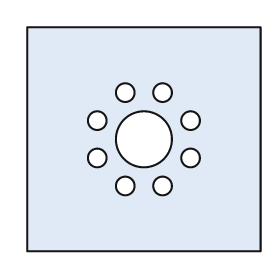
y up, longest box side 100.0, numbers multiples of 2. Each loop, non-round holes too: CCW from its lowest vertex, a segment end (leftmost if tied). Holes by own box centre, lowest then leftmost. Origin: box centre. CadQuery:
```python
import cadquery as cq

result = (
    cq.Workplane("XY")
    .moveTo(-50.0, -48.0)
    .lineTo(50.0, -48.0)
    .lineTo(50.0, 48.0)
    .lineTo(-50.0, 48.0)
    .close()
    .moveTo(-8.0, -20.0)
    .circle(4.0)
    .moveTo(8.0, -20.0)
    .circle(4.0)
    .moveTo(-20.0, -8.0)
    .circle(4.0)
    .moveTo(20.0, -8.0)
    .circle(4.0)
    .moveTo(0.0, 0.0)
    .circle(12.0)
    .moveTo(-20.0, 8.0)
    .circle(4.0)
    .moveTo(20.0, 8.0)
    .circle(4.0)
    .moveTo(-8.0, 20.0)
    .circle(4.0)
    .moveTo(8.0, 20.0)
    .circle(4.0)
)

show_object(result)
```